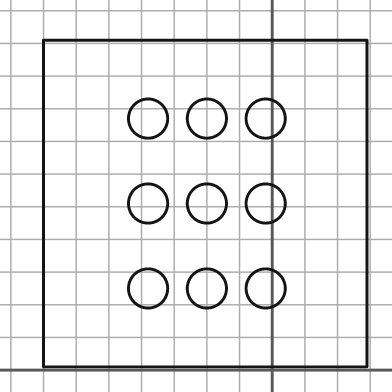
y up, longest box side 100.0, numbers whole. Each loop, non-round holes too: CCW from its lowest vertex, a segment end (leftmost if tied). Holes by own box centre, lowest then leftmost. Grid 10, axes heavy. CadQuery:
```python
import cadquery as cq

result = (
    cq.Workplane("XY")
    .moveTo(-70.0, 1.0)
    .lineTo(29.0, 1.0)
    .lineTo(29.0, 101.0)
    .lineTo(-70.0, 101.0)
    .close()
    .moveTo(-38.0, 25.0)
    .circle(6.0)
    .moveTo(-20.0, 25.0)
    .circle(6.0)
    .moveTo(-2.0, 25.0)
    .circle(6.0)
    .moveTo(-38.0, 51.0)
    .circle(6.0)
    .moveTo(-20.0, 51.0)
    .circle(6.0)
    .moveTo(-2.0, 51.0)
    .circle(6.0)
    .moveTo(-38.0, 77.0)
    .circle(6.0)
    .moveTo(-20.0, 77.0)
    .circle(6.0)
    .moveTo(-2.0, 77.0)
    .circle(6.0)
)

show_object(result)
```